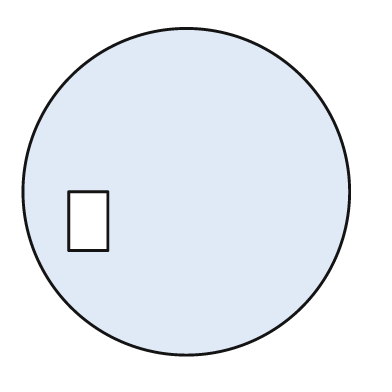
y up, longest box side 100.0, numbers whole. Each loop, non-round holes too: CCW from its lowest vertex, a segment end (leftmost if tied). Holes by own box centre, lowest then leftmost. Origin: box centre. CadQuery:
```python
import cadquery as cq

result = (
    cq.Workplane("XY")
    .moveTo(0.0, 0.0)
    .circle(50.0)
    .moveTo(-36.0, -18.0)
    .lineTo(-24.0, -18.0)
    .lineTo(-24.0, 0.0)
    .lineTo(-36.0, 0.0)
    .close()
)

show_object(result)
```